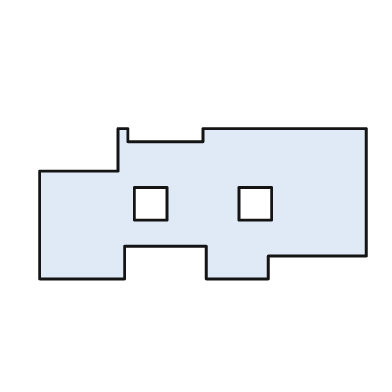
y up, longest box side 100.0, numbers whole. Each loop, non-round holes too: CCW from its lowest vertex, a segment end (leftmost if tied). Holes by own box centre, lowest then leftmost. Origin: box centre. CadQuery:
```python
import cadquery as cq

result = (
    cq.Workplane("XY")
    .moveTo(-50.0, -23.0)
    .lineTo(-24.0, -23.0)
    .lineTo(-24.0, -13.0)
    .lineTo(1.0, -13.0)
    .lineTo(1.0, -23.0)
    .lineTo(20.0, -23.0)
    .lineTo(20.0, -16.0)
    .lineTo(50.0, -16.0)
    .lineTo(50.0, 23.0)
    .lineTo(0.0, 23.0)
    .lineTo(0.0, 19.0)
    .lineTo(-23.0, 19.0)
    .lineTo(-23.0, 23.0)
    .lineTo(-26.0, 23.0)
    .lineTo(-26.0, 10.0)
    .lineTo(-50.0, 10.0)
    .close()
    .moveTo(-21.0, -5.0)
    .lineTo(-11.0, -5.0)
    .lineTo(-11.0, 5.0)
    .lineTo(-21.0, 5.0)
    .close()
    .moveTo(11.0, -5.0)
    .lineTo(21.0, -5.0)
    .lineTo(21.0, 5.0)
    .lineTo(11.0, 5.0)
    .close()
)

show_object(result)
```